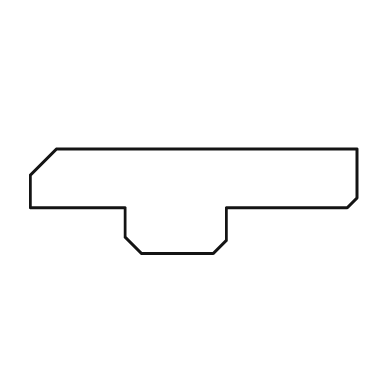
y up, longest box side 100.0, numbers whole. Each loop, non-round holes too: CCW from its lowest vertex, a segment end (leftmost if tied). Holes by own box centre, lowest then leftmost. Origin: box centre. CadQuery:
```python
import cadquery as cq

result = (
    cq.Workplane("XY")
    .moveTo(-16.0, -16.0)
    .lineTo(6.0, -16.0)
    .lineTo(10.0, -12.0)
    .lineTo(10.0, -2.0)
    .lineTo(47.0, -2.0)
    .lineTo(50.0, 1.0)
    .lineTo(50.0, 16.0)
    .lineTo(-42.0, 16.0)
    .lineTo(-50.0, 8.0)
    .lineTo(-50.0, -2.0)
    .lineTo(-21.0, -2.0)
    .lineTo(-21.0, -11.0)
    .close()
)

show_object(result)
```